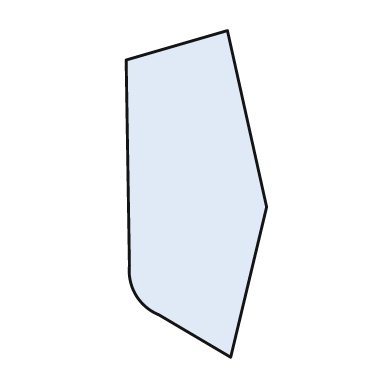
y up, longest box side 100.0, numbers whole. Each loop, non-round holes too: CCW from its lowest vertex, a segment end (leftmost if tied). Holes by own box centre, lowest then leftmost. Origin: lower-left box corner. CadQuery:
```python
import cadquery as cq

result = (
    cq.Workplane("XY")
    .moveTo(32.0, 0.0)
    .lineTo(43.0, 46.0)
    .lineTo(31.0, 100.0)
    .lineTo(0.0, 91.0)
    .lineTo(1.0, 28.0)
    .threePointArc((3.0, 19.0), (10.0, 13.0))
    .close()
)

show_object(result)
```